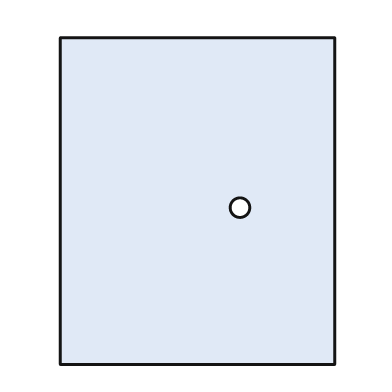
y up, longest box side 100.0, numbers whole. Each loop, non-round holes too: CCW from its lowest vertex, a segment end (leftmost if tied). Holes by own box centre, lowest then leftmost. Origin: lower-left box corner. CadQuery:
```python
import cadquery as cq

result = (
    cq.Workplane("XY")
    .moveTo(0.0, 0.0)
    .lineTo(84.0, 0.0)
    .lineTo(84.0, 100.0)
    .lineTo(0.0, 100.0)
    .close()
    .moveTo(55.0, 48.0)
    .circle(3.0)
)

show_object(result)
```